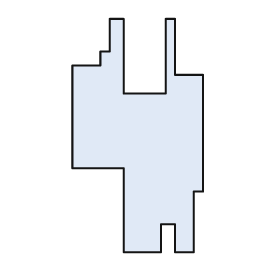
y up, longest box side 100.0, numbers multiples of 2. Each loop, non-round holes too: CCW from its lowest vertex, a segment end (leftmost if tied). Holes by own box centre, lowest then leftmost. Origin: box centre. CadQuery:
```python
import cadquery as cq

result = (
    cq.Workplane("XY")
    .moveTo(-6.0, -50.0)
    .lineTo(10.0, -50.0)
    .lineTo(10.0, -38.0)
    .lineTo(16.0, -38.0)
    .lineTo(16.0, -50.0)
    .lineTo(24.0, -50.0)
    .lineTo(24.0, -24.0)
    .lineTo(28.0, -24.0)
    .lineTo(28.0, 26.0)
    .lineTo(16.0, 26.0)
    .lineTo(16.0, 50.0)
    .lineTo(12.0, 50.0)
    .lineTo(12.0, 18.0)
    .lineTo(-6.0, 18.0)
    .lineTo(-6.0, 50.0)
    .lineTo(-12.0, 50.0)
    .lineTo(-12.0, 36.0)
    .lineTo(-16.0, 36.0)
    .lineTo(-16.0, 30.0)
    .lineTo(-28.0, 30.0)
    .lineTo(-28.0, -14.0)
    .lineTo(-6.0, -14.0)
    .close()
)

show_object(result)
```